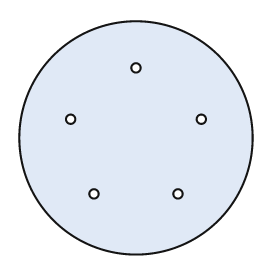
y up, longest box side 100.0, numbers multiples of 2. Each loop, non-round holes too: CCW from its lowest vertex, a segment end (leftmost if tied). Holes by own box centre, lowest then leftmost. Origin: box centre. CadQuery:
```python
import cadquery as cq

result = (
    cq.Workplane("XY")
    .moveTo(0.0, 0.0)
    .circle(50.0)
    .moveTo(-18.0, -24.0)
    .circle(2.0)
    .moveTo(18.0, -24.0)
    .circle(2.0)
    .moveTo(-28.0, 8.0)
    .circle(2.0)
    .moveTo(28.0, 8.0)
    .circle(2.0)
    .moveTo(0.0, 30.0)
    .circle(2.0)
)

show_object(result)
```